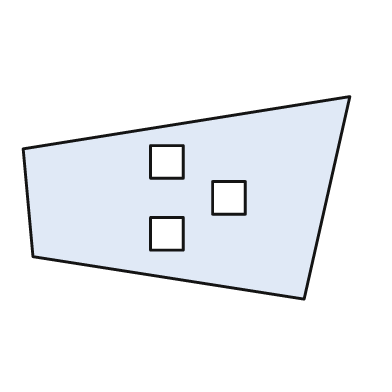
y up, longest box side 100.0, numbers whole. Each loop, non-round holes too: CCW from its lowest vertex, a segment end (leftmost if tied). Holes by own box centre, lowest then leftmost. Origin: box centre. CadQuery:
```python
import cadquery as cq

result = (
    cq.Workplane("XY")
    .moveTo(36.0, -31.0)
    .lineTo(50.0, 31.0)
    .lineTo(-50.0, 15.0)
    .lineTo(-47.0, -18.0)
    .close()
    .moveTo(-11.0, -16.0)
    .lineTo(-1.0, -16.0)
    .lineTo(-1.0, -6.0)
    .lineTo(-11.0, -6.0)
    .close()
    .moveTo(8.0, -5.0)
    .lineTo(18.0, -5.0)
    .lineTo(18.0, 5.0)
    .lineTo(8.0, 5.0)
    .close()
    .moveTo(-11.0, 6.0)
    .lineTo(-1.0, 6.0)
    .lineTo(-1.0, 16.0)
    .lineTo(-11.0, 16.0)
    .close()
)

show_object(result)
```